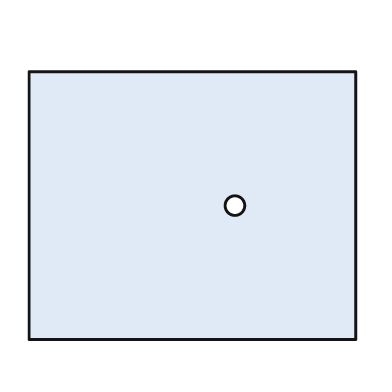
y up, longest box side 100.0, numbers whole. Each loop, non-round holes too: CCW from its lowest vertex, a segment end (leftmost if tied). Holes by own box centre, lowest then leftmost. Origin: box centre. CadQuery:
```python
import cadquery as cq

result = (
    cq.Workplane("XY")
    .moveTo(-50.0, -41.0)
    .lineTo(50.0, -41.0)
    .lineTo(50.0, 41.0)
    .lineTo(-50.0, 41.0)
    .close()
    .moveTo(13.0, 0.0)
    .circle(3.0)
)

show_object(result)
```